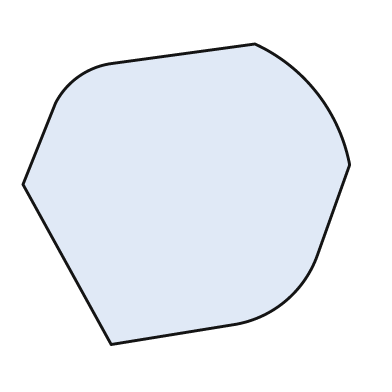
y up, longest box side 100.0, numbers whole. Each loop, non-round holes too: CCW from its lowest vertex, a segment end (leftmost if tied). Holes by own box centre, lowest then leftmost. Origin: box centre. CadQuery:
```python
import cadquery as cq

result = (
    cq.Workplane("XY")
    .moveTo(-23.0, -46.0)
    .lineTo(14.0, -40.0)
    .threePointArc((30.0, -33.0), (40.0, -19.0))
    .lineTo(50.0, 9.0)
    .threePointArc((40.0, 31.0), (21.0, 46.0))
    .lineTo(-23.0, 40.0)
    .threePointArc((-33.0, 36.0), (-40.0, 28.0))
    .lineTo(-50.0, 3.0)
    .close()
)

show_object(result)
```